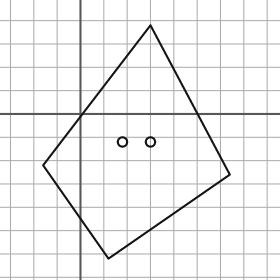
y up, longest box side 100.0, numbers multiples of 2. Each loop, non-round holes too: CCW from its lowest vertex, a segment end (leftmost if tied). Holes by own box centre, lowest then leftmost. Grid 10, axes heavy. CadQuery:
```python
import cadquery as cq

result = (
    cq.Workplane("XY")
    .moveTo(12.0, -62.0)
    .lineTo(64.0, -26.0)
    .lineTo(30.0, 38.0)
    .lineTo(-16.0, -22.0)
    .close()
    .moveTo(18.0, -12.0)
    .circle(2.0)
    .moveTo(30.0, -12.0)
    .circle(2.0)
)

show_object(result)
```